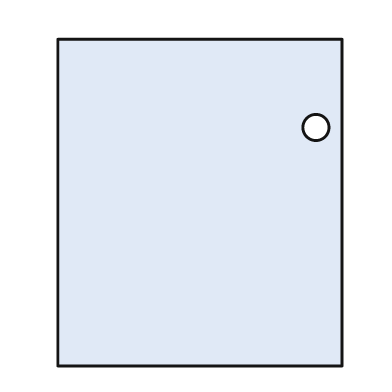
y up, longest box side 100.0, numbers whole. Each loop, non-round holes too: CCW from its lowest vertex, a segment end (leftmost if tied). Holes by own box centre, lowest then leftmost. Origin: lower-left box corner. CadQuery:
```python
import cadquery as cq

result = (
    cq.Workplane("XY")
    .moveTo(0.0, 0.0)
    .lineTo(87.0, 0.0)
    .lineTo(87.0, 100.0)
    .lineTo(0.0, 100.0)
    .close()
    .moveTo(79.0, 73.0)
    .circle(4.0)
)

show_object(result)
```